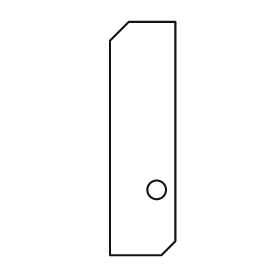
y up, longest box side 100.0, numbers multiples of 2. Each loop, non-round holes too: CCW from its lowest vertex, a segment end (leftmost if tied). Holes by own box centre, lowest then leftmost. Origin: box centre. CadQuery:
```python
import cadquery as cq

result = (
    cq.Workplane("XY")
    .moveTo(-14.0, -50.0)
    .lineTo(8.0, -50.0)
    .lineTo(14.0, -44.0)
    .lineTo(14.0, 50.0)
    .lineTo(-6.0, 50.0)
    .lineTo(-14.0, 42.0)
    .close()
    .moveTo(6.0, -22.0)
    .circle(4.0)
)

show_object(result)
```